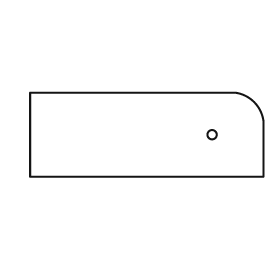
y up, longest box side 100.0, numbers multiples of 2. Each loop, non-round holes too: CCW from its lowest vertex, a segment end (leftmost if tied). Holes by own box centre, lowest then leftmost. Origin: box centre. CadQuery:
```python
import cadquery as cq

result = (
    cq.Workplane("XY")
    .moveTo(-50.0, -18.0)
    .lineTo(50.0, -18.0)
    .lineTo(50.0, 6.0)
    .threePointArc((46.0, 14.0), (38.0, 18.0))
    .lineTo(-50.0, 18.0)
    .close()
    .moveTo(28.0, 0.0)
    .circle(2.0)
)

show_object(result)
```